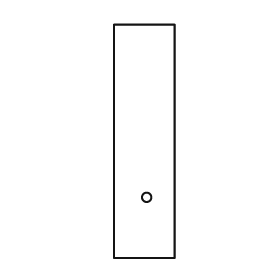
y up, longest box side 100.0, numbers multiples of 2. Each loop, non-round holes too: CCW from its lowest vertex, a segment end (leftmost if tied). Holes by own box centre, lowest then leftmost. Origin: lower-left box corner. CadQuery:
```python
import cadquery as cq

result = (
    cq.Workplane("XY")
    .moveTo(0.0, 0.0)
    .lineTo(26.0, 0.0)
    .lineTo(26.0, 100.0)
    .lineTo(0.0, 100.0)
    .close()
    .moveTo(14.0, 26.0)
    .circle(2.0)
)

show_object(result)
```